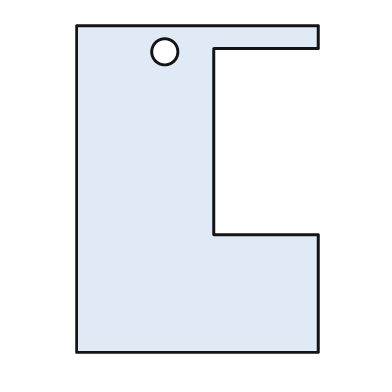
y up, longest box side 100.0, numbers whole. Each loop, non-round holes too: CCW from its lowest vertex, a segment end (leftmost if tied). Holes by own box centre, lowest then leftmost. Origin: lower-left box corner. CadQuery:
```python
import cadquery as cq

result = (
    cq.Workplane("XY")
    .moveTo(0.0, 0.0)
    .lineTo(74.0, 0.0)
    .lineTo(74.0, 36.0)
    .lineTo(42.0, 36.0)
    .lineTo(42.0, 93.0)
    .lineTo(74.0, 93.0)
    .lineTo(74.0, 100.0)
    .lineTo(0.0, 100.0)
    .close()
    .moveTo(27.0, 92.0)
    .circle(4.0)
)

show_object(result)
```